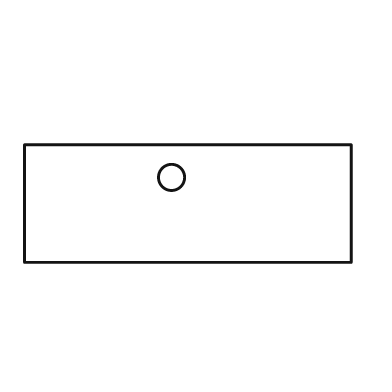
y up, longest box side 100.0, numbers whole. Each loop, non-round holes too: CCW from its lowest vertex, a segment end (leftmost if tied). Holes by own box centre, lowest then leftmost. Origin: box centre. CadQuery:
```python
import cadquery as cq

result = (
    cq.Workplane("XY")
    .moveTo(-50.0, -18.0)
    .lineTo(50.0, -18.0)
    .lineTo(50.0, 18.0)
    .lineTo(-50.0, 18.0)
    .close()
    .moveTo(-5.0, 8.0)
    .circle(4.0)
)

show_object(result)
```